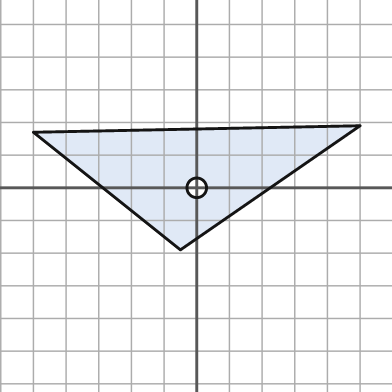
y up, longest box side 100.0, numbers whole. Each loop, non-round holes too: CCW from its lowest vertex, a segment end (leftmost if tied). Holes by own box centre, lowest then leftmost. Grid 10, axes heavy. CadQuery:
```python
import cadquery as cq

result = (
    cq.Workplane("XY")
    .moveTo(-5.0, -19.0)
    .lineTo(50.0, 19.0)
    .lineTo(-50.0, 17.0)
    .close()
    .moveTo(0.0, 0.0)
    .circle(3.0)
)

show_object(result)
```